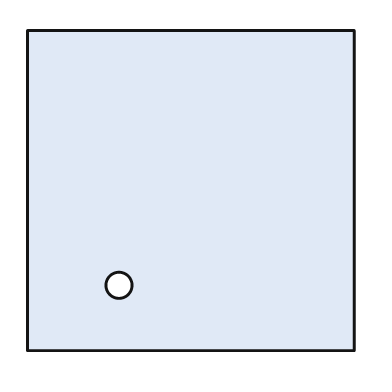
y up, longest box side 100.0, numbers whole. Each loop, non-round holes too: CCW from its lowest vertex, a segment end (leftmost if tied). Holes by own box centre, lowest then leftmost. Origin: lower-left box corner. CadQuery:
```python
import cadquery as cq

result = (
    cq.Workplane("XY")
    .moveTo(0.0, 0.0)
    .lineTo(100.0, 0.0)
    .lineTo(100.0, 98.0)
    .lineTo(0.0, 98.0)
    .close()
    .moveTo(28.0, 20.0)
    .circle(4.0)
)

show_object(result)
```